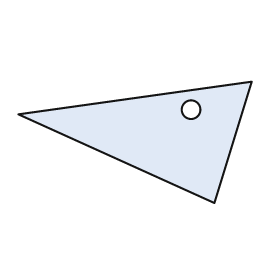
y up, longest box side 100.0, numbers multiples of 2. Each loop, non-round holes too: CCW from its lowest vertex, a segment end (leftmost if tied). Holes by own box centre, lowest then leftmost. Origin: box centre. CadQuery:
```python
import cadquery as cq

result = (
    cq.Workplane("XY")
    .moveTo(34.0, -26.0)
    .lineTo(50.0, 26.0)
    .lineTo(-50.0, 12.0)
    .close()
    .moveTo(24.0, 14.0)
    .circle(4.0)
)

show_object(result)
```